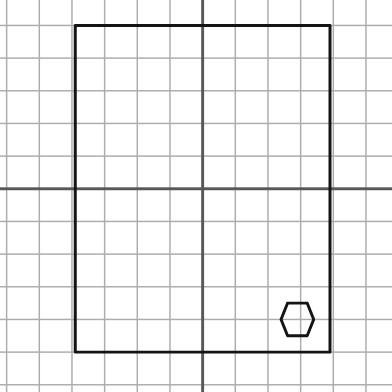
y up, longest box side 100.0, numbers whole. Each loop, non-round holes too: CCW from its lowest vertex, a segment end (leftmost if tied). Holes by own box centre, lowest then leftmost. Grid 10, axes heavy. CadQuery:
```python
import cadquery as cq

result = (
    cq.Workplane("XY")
    .moveTo(-39.0, -50.0)
    .lineTo(39.0, -50.0)
    .lineTo(39.0, 50.0)
    .lineTo(-39.0, 50.0)
    .close()
    .moveTo(26.0, -45.0)
    .lineTo(32.0, -45.0)
    .lineTo(34.0, -40.0)
    .lineTo(32.0, -35.0)
    .lineTo(26.0, -35.0)
    .lineTo(24.0, -40.0)
    .close()
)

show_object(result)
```